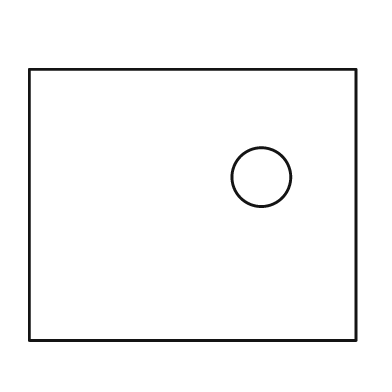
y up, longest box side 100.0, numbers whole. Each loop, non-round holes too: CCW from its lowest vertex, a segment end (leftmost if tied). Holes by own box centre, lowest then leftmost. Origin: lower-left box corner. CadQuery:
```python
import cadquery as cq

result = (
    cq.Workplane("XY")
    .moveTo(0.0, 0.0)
    .lineTo(100.0, 0.0)
    .lineTo(100.0, 83.0)
    .lineTo(0.0, 83.0)
    .close()
    .moveTo(71.0, 50.0)
    .circle(9.0)
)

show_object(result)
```